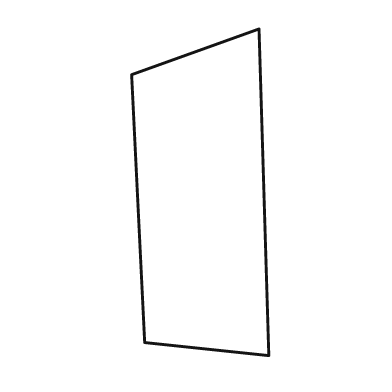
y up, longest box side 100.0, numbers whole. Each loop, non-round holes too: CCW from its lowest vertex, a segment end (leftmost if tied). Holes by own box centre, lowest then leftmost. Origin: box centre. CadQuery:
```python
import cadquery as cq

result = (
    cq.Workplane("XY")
    .moveTo(21.0, -50.0)
    .lineTo(18.0, 50.0)
    .lineTo(-21.0, 36.0)
    .lineTo(-17.0, -46.0)
    .close()
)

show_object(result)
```